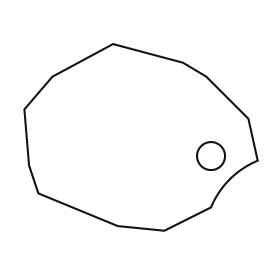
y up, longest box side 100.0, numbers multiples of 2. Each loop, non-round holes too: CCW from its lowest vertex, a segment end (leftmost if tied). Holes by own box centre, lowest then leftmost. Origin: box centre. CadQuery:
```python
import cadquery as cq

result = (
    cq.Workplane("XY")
    .moveTo(10.0, -40.0)
    .lineTo(30.0, -30.0)
    .threePointArc((38.0, -18.0), (50.0, -10.0))
    .lineTo(46.0, 8.0)
    .lineTo(28.0, 26.0)
    .lineTo(18.0, 32.0)
    .lineTo(-12.0, 40.0)
    .lineTo(-38.0, 26.0)
    .lineTo(-50.0, 12.0)
    .lineTo(-48.0, -12.0)
    .lineTo(-44.0, -24.0)
    .lineTo(-10.0, -38.0)
    .close()
    .moveTo(30.0, -8.0)
    .circle(6.0)
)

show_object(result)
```